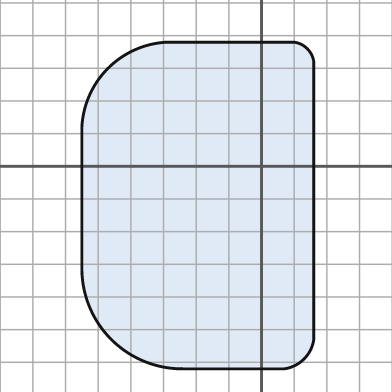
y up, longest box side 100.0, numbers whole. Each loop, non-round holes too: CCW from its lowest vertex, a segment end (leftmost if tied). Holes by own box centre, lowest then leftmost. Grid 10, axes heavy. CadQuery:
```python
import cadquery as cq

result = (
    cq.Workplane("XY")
    .moveTo(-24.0, -62.0)
    .lineTo(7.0, -62.0)
    .threePointArc((13.0, -59.0), (16.0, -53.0))
    .lineTo(16.0, 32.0)
    .threePointArc((14.0, 36.0), (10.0, 38.0))
    .lineTo(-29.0, 38.0)
    .threePointArc((-47.0, 30.0), (-55.0, 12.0))
    .lineTo(-55.0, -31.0)
    .threePointArc((-46.0, -53.0), (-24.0, -62.0))
    .close()
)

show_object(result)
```